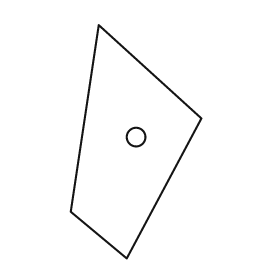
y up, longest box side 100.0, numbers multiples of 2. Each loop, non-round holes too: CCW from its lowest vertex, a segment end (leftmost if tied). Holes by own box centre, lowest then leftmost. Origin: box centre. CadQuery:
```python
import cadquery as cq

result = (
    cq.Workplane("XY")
    .moveTo(-4.0, -50.0)
    .lineTo(28.0, 10.0)
    .lineTo(-16.0, 50.0)
    .lineTo(-28.0, -30.0)
    .close()
    .moveTo(0.0, 2.0)
    .circle(4.0)
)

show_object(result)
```